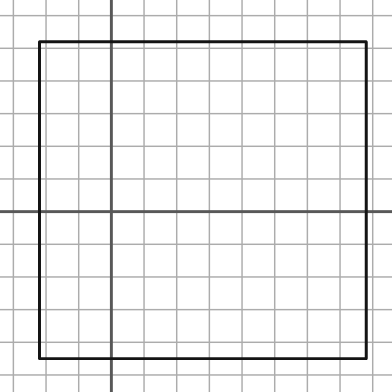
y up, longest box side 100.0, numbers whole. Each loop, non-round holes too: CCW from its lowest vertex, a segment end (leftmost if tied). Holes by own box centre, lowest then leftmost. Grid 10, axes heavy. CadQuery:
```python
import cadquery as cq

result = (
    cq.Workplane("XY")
    .moveTo(-22.0, -45.0)
    .lineTo(78.0, -45.0)
    .lineTo(78.0, 52.0)
    .lineTo(-22.0, 52.0)
    .close()
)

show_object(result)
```